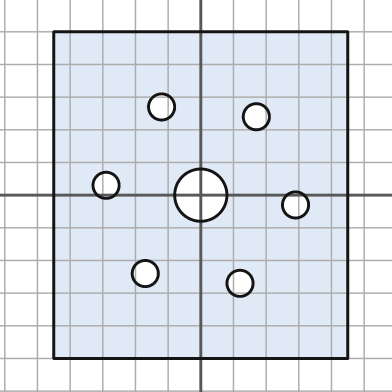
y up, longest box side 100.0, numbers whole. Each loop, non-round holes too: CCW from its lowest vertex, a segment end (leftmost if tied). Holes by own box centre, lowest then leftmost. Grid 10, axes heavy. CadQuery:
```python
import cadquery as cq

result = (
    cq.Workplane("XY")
    .moveTo(-45.0, -50.0)
    .lineTo(45.0, -50.0)
    .lineTo(45.0, 50.0)
    .lineTo(-45.0, 50.0)
    .close()
    .moveTo(12.0, -27.0)
    .circle(4.0)
    .moveTo(-17.0, -24.0)
    .circle(4.0)
    .moveTo(29.0, -3.0)
    .circle(4.0)
    .moveTo(0.0, 0.0)
    .circle(8.0)
    .moveTo(-29.0, 3.0)
    .circle(4.0)
    .moveTo(17.0, 24.0)
    .circle(4.0)
    .moveTo(-12.0, 27.0)
    .circle(4.0)
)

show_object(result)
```